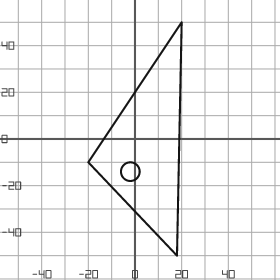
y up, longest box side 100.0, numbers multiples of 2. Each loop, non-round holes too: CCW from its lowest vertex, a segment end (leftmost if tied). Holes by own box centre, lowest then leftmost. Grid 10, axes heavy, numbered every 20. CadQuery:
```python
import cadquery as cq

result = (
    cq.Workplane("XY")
    .moveTo(18.0, -50.0)
    .lineTo(20.0, 50.0)
    .lineTo(-20.0, -10.0)
    .close()
    .moveTo(-2.0, -14.0)
    .circle(4.0)
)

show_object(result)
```